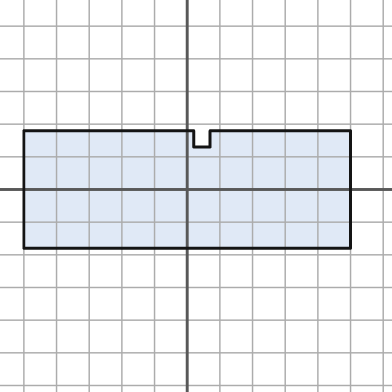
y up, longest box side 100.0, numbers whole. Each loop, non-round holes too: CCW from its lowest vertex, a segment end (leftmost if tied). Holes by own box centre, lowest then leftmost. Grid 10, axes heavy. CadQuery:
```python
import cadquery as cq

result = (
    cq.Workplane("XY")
    .moveTo(-50.0, -18.0)
    .lineTo(50.0, -18.0)
    .lineTo(50.0, 18.0)
    .lineTo(7.0, 18.0)
    .lineTo(7.0, 13.0)
    .lineTo(2.0, 13.0)
    .lineTo(2.0, 18.0)
    .lineTo(-50.0, 18.0)
    .close()
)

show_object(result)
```